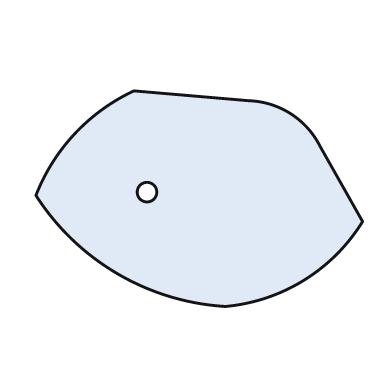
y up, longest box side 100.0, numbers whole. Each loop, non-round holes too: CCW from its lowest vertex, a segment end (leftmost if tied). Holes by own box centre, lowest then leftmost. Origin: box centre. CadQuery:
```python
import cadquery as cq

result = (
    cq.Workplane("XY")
    .moveTo(8.0, -33.0)
    .threePointArc((32.0, -25.0), (50.0, -7.0))
    .lineTo(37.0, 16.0)
    .threePointArc((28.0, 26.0), (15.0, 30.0))
    .lineTo(-20.0, 33.0)
    .threePointArc((-38.0, 20.0), (-50.0, 1.0))
    .threePointArc((-25.0, -23.0), (8.0, -33.0))
    .close()
    .moveTo(-16.0, 2.0)
    .circle(3.0)
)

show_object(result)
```